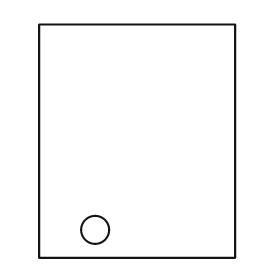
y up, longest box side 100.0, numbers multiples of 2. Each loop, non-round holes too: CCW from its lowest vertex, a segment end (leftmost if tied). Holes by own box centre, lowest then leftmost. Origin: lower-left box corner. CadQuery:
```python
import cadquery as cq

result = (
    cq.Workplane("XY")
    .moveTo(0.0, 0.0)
    .lineTo(84.0, 0.0)
    .lineTo(84.0, 100.0)
    .lineTo(0.0, 100.0)
    .close()
    .moveTo(24.0, 12.0)
    .circle(6.0)
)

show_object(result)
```